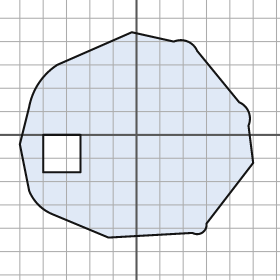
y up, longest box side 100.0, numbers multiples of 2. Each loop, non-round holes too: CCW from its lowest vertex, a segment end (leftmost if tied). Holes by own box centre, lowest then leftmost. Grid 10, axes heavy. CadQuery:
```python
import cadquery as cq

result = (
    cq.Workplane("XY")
    .moveTo(-12.0, -44.0)
    .lineTo(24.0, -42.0)
    .threePointArc((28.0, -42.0), (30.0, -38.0))
    .lineTo(50.0, -12.0)
    .lineTo(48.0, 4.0)
    .threePointArc((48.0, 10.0), (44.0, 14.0))
    .lineTo(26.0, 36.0)
    .threePointArc((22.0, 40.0), (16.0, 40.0))
    .lineTo(-2.0, 44.0)
    .lineTo(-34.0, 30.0)
    .threePointArc((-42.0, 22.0), (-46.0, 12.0))
    .lineTo(-50.0, -4.0)
    .lineTo(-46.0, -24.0)
    .threePointArc((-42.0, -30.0), (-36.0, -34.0))
    .close()
    .moveTo(-40.0, -16.0)
    .lineTo(-24.0, -16.0)
    .lineTo(-24.0, 0.0)
    .lineTo(-40.0, 0.0)
    .close()
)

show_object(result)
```